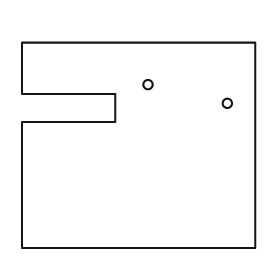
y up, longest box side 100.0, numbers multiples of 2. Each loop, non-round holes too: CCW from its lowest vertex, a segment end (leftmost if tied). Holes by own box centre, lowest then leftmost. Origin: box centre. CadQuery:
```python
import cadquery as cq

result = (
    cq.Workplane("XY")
    .moveTo(-50.0, -44.0)
    .lineTo(50.0, -44.0)
    .lineTo(50.0, 44.0)
    .lineTo(-50.0, 44.0)
    .lineTo(-50.0, 22.0)
    .lineTo(-10.0, 22.0)
    .lineTo(-10.0, 10.0)
    .lineTo(-50.0, 10.0)
    .close()
    .moveTo(38.0, 18.0)
    .circle(2.0)
    .moveTo(4.0, 26.0)
    .circle(2.0)
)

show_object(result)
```